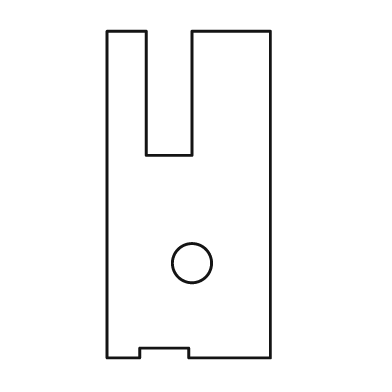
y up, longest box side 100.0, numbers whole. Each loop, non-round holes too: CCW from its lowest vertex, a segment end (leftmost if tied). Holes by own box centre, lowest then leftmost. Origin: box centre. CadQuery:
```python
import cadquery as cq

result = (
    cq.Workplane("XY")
    .moveTo(-25.0, -50.0)
    .lineTo(-15.0, -50.0)
    .lineTo(-15.0, -47.0)
    .lineTo(0.0, -47.0)
    .lineTo(0.0, -50.0)
    .lineTo(25.0, -50.0)
    .lineTo(25.0, 50.0)
    .lineTo(1.0, 50.0)
    .lineTo(1.0, 12.0)
    .lineTo(-13.0, 12.0)
    .lineTo(-13.0, 50.0)
    .lineTo(-25.0, 50.0)
    .close()
    .moveTo(1.0, -21.0)
    .circle(6.0)
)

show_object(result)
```